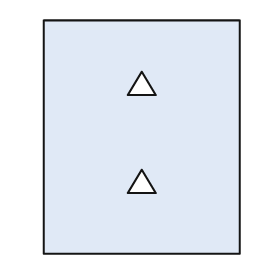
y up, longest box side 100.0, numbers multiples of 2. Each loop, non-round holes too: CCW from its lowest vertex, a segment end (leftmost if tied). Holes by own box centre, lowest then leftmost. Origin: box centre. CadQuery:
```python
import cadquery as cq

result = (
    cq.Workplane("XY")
    .moveTo(-42.0, -50.0)
    .lineTo(42.0, -50.0)
    .lineTo(42.0, 50.0)
    .lineTo(-42.0, 50.0)
    .close()
    .moveTo(-6.0, -24.0)
    .lineTo(6.0, -24.0)
    .lineTo(0.0, -14.0)
    .close()
    .moveTo(-6.0, 18.0)
    .lineTo(6.0, 18.0)
    .lineTo(0.0, 28.0)
    .close()
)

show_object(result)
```